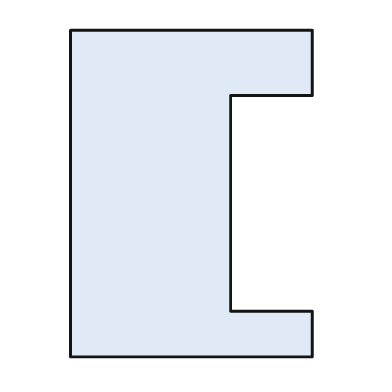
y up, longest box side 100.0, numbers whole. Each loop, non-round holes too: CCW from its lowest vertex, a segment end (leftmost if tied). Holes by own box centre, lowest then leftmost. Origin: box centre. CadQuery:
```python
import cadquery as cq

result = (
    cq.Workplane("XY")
    .moveTo(-37.0, -50.0)
    .lineTo(37.0, -50.0)
    .lineTo(37.0, -36.0)
    .lineTo(12.0, -36.0)
    .lineTo(12.0, 30.0)
    .lineTo(37.0, 30.0)
    .lineTo(37.0, 50.0)
    .lineTo(-37.0, 50.0)
    .close()
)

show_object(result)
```